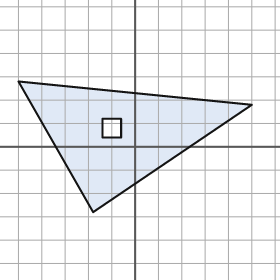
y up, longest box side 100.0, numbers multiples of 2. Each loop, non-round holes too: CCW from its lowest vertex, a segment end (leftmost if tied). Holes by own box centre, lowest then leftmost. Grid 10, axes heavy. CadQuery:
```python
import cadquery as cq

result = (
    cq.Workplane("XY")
    .moveTo(-18.0, -28.0)
    .lineTo(50.0, 18.0)
    .lineTo(-50.0, 28.0)
    .close()
    .moveTo(-14.0, 4.0)
    .lineTo(-6.0, 4.0)
    .lineTo(-6.0, 12.0)
    .lineTo(-14.0, 12.0)
    .close()
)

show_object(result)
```